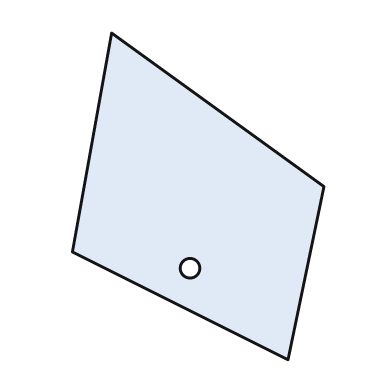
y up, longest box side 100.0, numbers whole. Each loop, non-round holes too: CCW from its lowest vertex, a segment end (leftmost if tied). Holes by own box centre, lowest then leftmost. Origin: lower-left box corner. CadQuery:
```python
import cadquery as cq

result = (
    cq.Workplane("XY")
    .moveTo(66.0, 0.0)
    .lineTo(77.0, 53.0)
    .lineTo(12.0, 100.0)
    .lineTo(0.0, 33.0)
    .close()
    .moveTo(36.0, 28.0)
    .circle(3.0)
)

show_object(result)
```